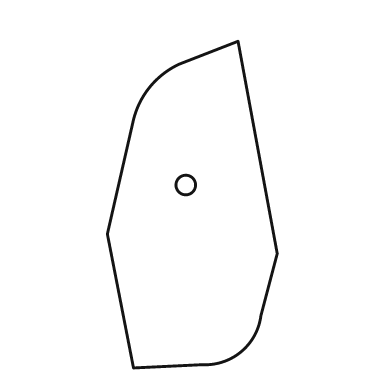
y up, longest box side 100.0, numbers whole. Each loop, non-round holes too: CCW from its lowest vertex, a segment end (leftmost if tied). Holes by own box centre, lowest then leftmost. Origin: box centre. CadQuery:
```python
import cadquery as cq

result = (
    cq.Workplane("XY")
    .moveTo(-18.0, -50.0)
    .lineTo(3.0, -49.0)
    .threePointArc((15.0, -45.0), (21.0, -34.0))
    .lineTo(26.0, -15.0)
    .lineTo(14.0, 50.0)
    .lineTo(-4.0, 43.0)
    .threePointArc((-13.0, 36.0), (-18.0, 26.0))
    .lineTo(-26.0, -9.0)
    .close()
    .moveTo(-2.0, 6.0)
    .circle(3.0)
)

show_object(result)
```